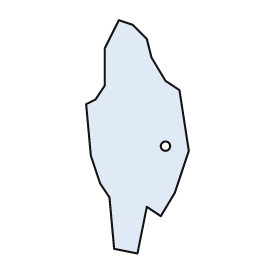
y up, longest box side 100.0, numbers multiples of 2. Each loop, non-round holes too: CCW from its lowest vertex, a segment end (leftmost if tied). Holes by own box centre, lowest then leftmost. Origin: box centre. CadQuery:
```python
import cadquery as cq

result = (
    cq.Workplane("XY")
    .moveTo(0.0, -50.0)
    .lineTo(4.0, -30.0)
    .lineTo(10.0, -34.0)
    .lineTo(16.0, -24.0)
    .lineTo(22.0, -6.0)
    .lineTo(18.0, 20.0)
    .lineTo(12.0, 24.0)
    .lineTo(6.0, 34.0)
    .lineTo(4.0, 42.0)
    .lineTo(-2.0, 48.0)
    .lineTo(-8.0, 50.0)
    .lineTo(-14.0, 38.0)
    .lineTo(-14.0, 22.0)
    .lineTo(-18.0, 16.0)
    .lineTo(-22.0, 14.0)
    .lineTo(-20.0, -8.0)
    .lineTo(-16.0, -20.0)
    .lineTo(-12.0, -26.0)
    .lineTo(-10.0, -48.0)
    .close()
    .moveTo(12.0, -4.0)
    .circle(2.0)
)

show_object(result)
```